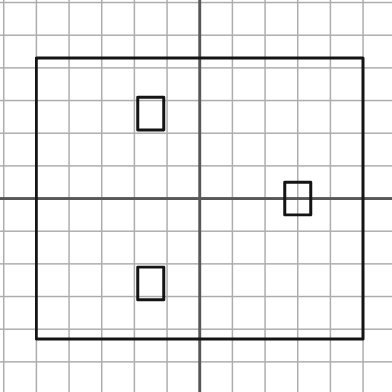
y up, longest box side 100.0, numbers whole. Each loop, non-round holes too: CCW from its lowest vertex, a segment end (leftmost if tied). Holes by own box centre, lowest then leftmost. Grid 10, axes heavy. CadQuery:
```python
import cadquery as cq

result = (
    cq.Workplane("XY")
    .moveTo(-50.0, -43.0)
    .lineTo(50.0, -43.0)
    .lineTo(50.0, 43.0)
    .lineTo(-50.0, 43.0)
    .close()
    .moveTo(-19.0, -31.0)
    .lineTo(-11.0, -31.0)
    .lineTo(-11.0, -21.0)
    .lineTo(-19.0, -21.0)
    .close()
    .moveTo(26.0, -5.0)
    .lineTo(34.0, -5.0)
    .lineTo(34.0, 5.0)
    .lineTo(26.0, 5.0)
    .close()
    .moveTo(-19.0, 21.0)
    .lineTo(-11.0, 21.0)
    .lineTo(-11.0, 31.0)
    .lineTo(-19.0, 31.0)
    .close()
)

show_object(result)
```